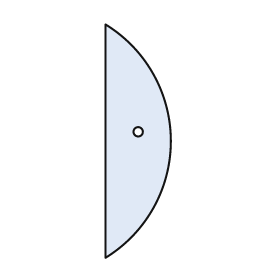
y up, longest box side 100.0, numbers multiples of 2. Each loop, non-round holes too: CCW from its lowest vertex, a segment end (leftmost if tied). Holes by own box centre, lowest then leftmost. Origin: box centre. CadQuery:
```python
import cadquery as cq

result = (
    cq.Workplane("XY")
    .moveTo(-14.0, -50.0)
    .threePointArc((14.0, 0.0), (-14.0, 50.0))
    .close()
    .moveTo(0.0, 4.0)
    .circle(2.0)
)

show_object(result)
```